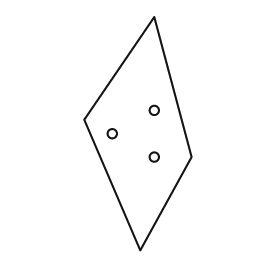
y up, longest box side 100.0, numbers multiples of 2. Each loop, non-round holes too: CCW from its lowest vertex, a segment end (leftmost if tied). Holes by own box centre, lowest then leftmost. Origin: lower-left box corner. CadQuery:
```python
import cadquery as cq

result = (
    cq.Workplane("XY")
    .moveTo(24.0, 0.0)
    .lineTo(46.0, 40.0)
    .lineTo(30.0, 100.0)
    .lineTo(0.0, 56.0)
    .close()
    .moveTo(30.0, 40.0)
    .circle(2.0)
    .moveTo(12.0, 50.0)
    .circle(2.0)
    .moveTo(30.0, 60.0)
    .circle(2.0)
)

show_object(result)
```